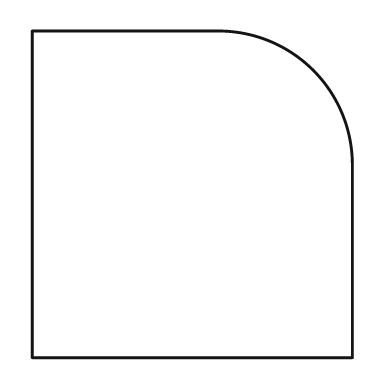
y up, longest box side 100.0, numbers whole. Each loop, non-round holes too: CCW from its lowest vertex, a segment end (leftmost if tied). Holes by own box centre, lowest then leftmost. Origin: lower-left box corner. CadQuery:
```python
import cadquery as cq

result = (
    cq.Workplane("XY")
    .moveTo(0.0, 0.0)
    .lineTo(98.0, 0.0)
    .lineTo(98.0, 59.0)
    .threePointArc((86.0, 88.0), (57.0, 100.0))
    .lineTo(0.0, 100.0)
    .close()
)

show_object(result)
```